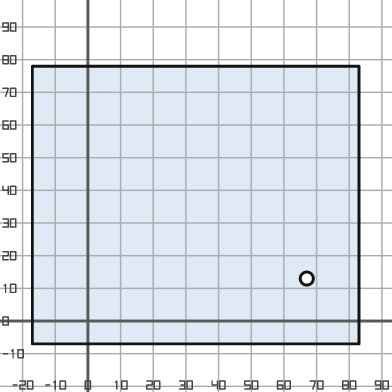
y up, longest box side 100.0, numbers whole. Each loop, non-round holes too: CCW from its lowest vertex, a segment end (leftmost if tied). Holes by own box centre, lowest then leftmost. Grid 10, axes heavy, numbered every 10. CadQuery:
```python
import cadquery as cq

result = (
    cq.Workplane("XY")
    .moveTo(-17.0, -7.0)
    .lineTo(83.0, -7.0)
    .lineTo(83.0, 78.0)
    .lineTo(-17.0, 78.0)
    .close()
    .moveTo(67.0, 13.0)
    .circle(2.0)
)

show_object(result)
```